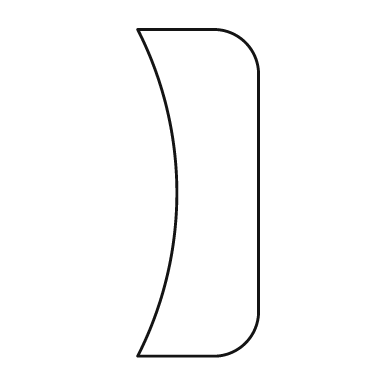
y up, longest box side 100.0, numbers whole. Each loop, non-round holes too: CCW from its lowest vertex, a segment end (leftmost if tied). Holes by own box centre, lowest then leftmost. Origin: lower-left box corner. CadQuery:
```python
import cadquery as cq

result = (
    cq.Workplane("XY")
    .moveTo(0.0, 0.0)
    .lineTo(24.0, 0.0)
    .threePointArc((33.0, 4.0), (37.0, 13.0))
    .lineTo(37.0, 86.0)
    .threePointArc((33.0, 96.0), (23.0, 100.0))
    .lineTo(0.0, 100.0)
    .threePointArc((12.0, 50.0), (0.0, 0.0))
    .close()
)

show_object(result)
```